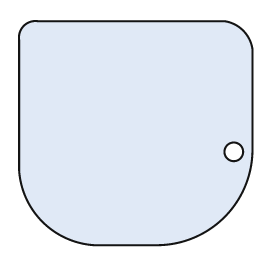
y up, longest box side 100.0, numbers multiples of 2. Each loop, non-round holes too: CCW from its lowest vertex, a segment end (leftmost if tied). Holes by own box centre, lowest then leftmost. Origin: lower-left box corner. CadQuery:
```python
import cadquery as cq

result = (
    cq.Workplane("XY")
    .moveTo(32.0, 0.0)
    .lineTo(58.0, 0.0)
    .threePointArc((88.0, 12.0), (100.0, 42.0))
    .lineTo(100.0, 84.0)
    .threePointArc((96.0, 92.0), (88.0, 96.0))
    .lineTo(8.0, 96.0)
    .threePointArc((2.0, 94.0), (0.0, 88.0))
    .lineTo(0.0, 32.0)
    .threePointArc((10.0, 10.0), (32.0, 0.0))
    .close()
    .moveTo(92.0, 40.0)
    .circle(4.0)
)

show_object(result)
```